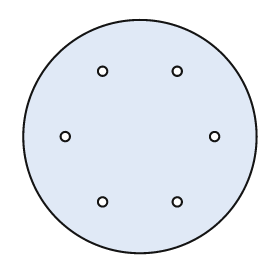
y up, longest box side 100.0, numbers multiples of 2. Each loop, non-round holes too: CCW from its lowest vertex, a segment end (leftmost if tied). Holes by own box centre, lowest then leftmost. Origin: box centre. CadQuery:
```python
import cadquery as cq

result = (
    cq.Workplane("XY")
    .moveTo(0.0, 0.0)
    .circle(50.0)
    .moveTo(-16.0, -28.0)
    .circle(2.0)
    .moveTo(16.0, -28.0)
    .circle(2.0)
    .moveTo(-32.0, 0.0)
    .circle(2.0)
    .moveTo(32.0, 0.0)
    .circle(2.0)
    .moveTo(-16.0, 28.0)
    .circle(2.0)
    .moveTo(16.0, 28.0)
    .circle(2.0)
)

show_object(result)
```